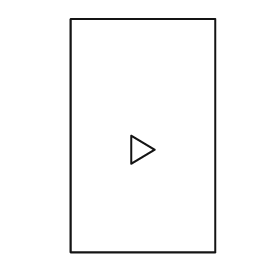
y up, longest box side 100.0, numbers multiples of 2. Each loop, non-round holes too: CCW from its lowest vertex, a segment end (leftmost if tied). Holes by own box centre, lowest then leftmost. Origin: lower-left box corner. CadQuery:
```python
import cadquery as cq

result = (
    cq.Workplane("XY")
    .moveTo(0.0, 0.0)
    .lineTo(62.0, 0.0)
    .lineTo(62.0, 100.0)
    .lineTo(0.0, 100.0)
    .close()
    .moveTo(26.0, 38.0)
    .lineTo(36.0, 44.0)
    .lineTo(26.0, 50.0)
    .close()
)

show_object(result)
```